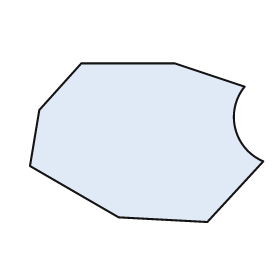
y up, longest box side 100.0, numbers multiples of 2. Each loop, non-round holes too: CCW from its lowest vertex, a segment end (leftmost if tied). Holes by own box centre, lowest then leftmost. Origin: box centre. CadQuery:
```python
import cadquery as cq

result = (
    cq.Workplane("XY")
    .moveTo(26.0, -34.0)
    .lineTo(50.0, -8.0)
    .threePointArc((38.0, 6.0), (42.0, 24.0))
    .lineTo(12.0, 34.0)
    .lineTo(-28.0, 34.0)
    .lineTo(-46.0, 14.0)
    .lineTo(-50.0, -10.0)
    .lineTo(-12.0, -32.0)
    .close()
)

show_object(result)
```